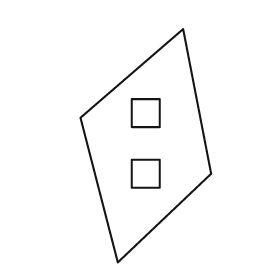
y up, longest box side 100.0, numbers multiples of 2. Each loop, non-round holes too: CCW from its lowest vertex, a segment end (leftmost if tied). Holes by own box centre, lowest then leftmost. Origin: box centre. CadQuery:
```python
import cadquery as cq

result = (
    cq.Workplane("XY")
    .moveTo(-12.0, -50.0)
    .lineTo(28.0, -12.0)
    .lineTo(16.0, 50.0)
    .lineTo(-28.0, 12.0)
    .close()
    .moveTo(-6.0, -18.0)
    .lineTo(6.0, -18.0)
    .lineTo(6.0, -6.0)
    .lineTo(-6.0, -6.0)
    .close()
    .moveTo(-6.0, 8.0)
    .lineTo(6.0, 8.0)
    .lineTo(6.0, 20.0)
    .lineTo(-6.0, 20.0)
    .close()
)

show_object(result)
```